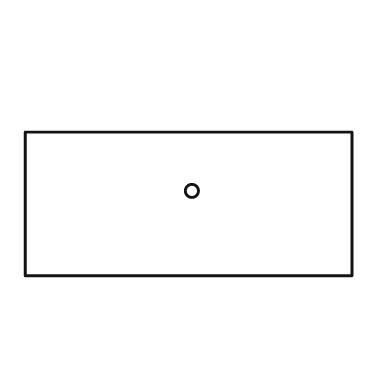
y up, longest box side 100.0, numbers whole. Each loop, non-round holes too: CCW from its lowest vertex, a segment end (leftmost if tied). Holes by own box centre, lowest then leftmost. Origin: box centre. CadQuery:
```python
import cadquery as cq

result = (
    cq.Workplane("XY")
    .moveTo(-50.0, -22.0)
    .lineTo(50.0, -22.0)
    .lineTo(50.0, 22.0)
    .lineTo(-50.0, 22.0)
    .close()
    .moveTo(1.0, 4.0)
    .circle(2.0)
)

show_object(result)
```